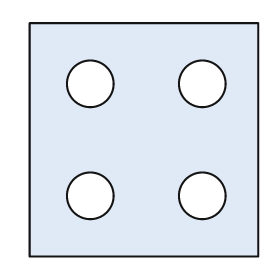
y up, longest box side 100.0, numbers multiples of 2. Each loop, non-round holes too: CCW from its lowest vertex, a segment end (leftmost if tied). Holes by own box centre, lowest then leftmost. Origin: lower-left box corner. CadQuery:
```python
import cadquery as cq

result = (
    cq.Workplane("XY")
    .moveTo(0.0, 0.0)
    .lineTo(98.0, 0.0)
    .lineTo(98.0, 100.0)
    .lineTo(0.0, 100.0)
    .close()
    .moveTo(26.0, 26.0)
    .circle(10.0)
    .moveTo(74.0, 26.0)
    .circle(10.0)
    .moveTo(26.0, 74.0)
    .circle(10.0)
    .moveTo(74.0, 74.0)
    .circle(10.0)
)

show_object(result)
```